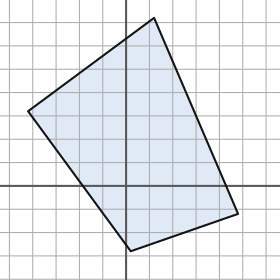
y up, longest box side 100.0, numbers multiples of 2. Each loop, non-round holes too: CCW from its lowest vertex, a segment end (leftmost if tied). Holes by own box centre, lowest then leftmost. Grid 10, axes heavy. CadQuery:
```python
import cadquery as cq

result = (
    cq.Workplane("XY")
    .moveTo(2.0, -28.0)
    .lineTo(48.0, -12.0)
    .lineTo(12.0, 72.0)
    .lineTo(-42.0, 32.0)
    .close()
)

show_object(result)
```